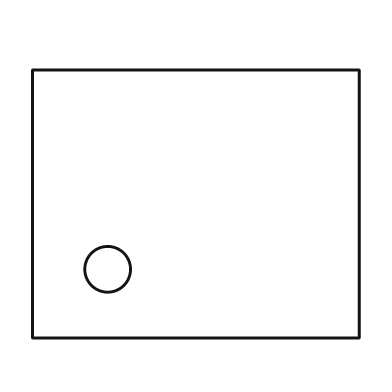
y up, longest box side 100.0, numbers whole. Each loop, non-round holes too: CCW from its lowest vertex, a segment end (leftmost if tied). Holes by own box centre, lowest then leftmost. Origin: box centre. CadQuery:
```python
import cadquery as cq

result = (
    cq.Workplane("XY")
    .moveTo(-50.0, -41.0)
    .lineTo(50.0, -41.0)
    .lineTo(50.0, 41.0)
    .lineTo(-50.0, 41.0)
    .close()
    .moveTo(-27.0, -20.0)
    .circle(7.0)
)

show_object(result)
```